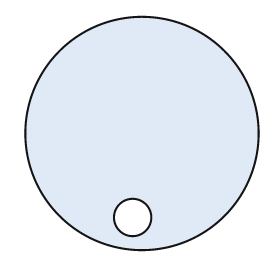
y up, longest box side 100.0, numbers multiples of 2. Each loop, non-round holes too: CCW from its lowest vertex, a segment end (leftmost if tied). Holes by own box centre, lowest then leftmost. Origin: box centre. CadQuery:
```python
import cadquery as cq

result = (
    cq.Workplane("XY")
    .moveTo(0.0, 0.0)
    .circle(50.0)
    .moveTo(-4.0, -36.0)
    .circle(8.0)
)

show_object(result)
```